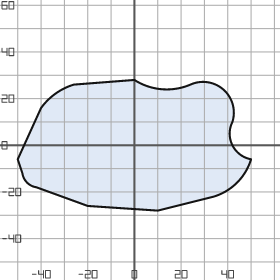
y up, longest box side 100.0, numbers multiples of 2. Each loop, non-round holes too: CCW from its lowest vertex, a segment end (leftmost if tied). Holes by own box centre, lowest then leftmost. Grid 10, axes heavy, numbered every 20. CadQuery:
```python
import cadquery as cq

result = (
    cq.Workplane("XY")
    .moveTo(10.0, -28.0)
    .lineTo(34.0, -22.0)
    .threePointArc((44.0, -16.0), (50.0, -6.0))
    .threePointArc((42.0, 0.0), (42.0, 10.0))
    .threePointArc((38.0, 24.0), (24.0, 26.0))
    .threePointArc((12.0, 24.0), (0.0, 28.0))
    .lineTo(-26.0, 26.0)
    .threePointArc((-34.0, 22.0), (-40.0, 16.0))
    .lineTo(-50.0, -6.0)
    .lineTo(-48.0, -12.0)
    .threePointArc((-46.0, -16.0), (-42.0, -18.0))
    .lineTo(-20.0, -26.0)
    .close()
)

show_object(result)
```